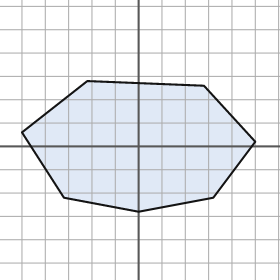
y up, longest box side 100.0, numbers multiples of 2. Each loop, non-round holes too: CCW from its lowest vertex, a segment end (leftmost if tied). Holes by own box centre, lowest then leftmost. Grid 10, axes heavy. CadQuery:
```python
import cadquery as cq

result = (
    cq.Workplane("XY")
    .moveTo(0.0, -28.0)
    .lineTo(32.0, -22.0)
    .lineTo(50.0, 2.0)
    .lineTo(28.0, 26.0)
    .lineTo(-22.0, 28.0)
    .lineTo(-50.0, 6.0)
    .lineTo(-32.0, -22.0)
    .close()
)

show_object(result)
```